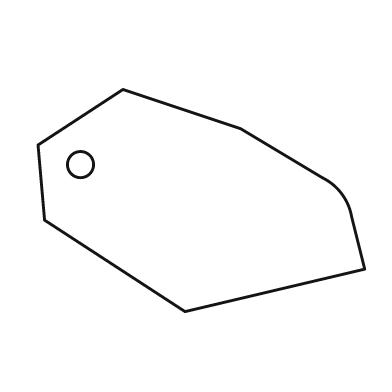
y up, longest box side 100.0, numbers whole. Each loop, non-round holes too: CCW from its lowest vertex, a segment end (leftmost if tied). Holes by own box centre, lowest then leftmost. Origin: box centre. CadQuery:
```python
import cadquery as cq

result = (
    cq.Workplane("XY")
    .moveTo(-5.0, -34.0)
    .lineTo(50.0, -21.0)
    .lineTo(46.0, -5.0)
    .threePointArc((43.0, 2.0), (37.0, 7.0))
    .lineTo(12.0, 22.0)
    .lineTo(-24.0, 34.0)
    .lineTo(-50.0, 17.0)
    .lineTo(-48.0, -6.0)
    .close()
    .moveTo(-37.0, 11.0)
    .circle(4.0)
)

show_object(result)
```